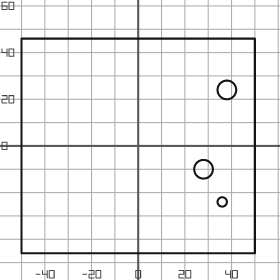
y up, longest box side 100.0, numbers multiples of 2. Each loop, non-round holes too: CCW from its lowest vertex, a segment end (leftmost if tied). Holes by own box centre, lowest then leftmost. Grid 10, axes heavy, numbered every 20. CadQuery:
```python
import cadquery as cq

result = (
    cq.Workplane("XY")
    .moveTo(-50.0, -46.0)
    .lineTo(50.0, -46.0)
    .lineTo(50.0, 46.0)
    .lineTo(-50.0, 46.0)
    .close()
    .moveTo(36.0, -24.0)
    .circle(2.0)
    .moveTo(28.0, -10.0)
    .circle(4.0)
    .moveTo(38.0, 24.0)
    .circle(4.0)
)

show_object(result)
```